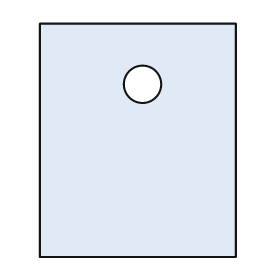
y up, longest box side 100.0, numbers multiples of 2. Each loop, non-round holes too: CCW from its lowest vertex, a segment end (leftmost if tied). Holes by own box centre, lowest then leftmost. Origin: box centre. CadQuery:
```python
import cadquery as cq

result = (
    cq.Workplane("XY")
    .moveTo(-42.0, -50.0)
    .lineTo(42.0, -50.0)
    .lineTo(42.0, 50.0)
    .lineTo(-42.0, 50.0)
    .close()
    .moveTo(2.0, 24.0)
    .circle(8.0)
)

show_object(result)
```